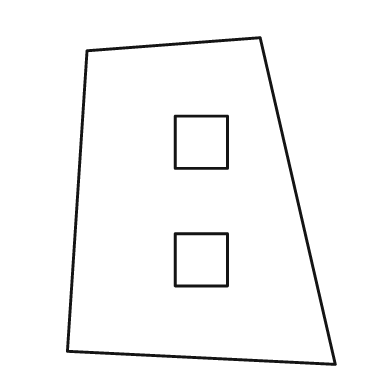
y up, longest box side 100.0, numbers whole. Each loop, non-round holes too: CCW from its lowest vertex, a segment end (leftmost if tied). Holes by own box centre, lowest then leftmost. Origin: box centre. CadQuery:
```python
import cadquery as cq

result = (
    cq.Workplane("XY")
    .moveTo(41.0, -50.0)
    .lineTo(18.0, 50.0)
    .lineTo(-35.0, 46.0)
    .lineTo(-41.0, -46.0)
    .close()
    .moveTo(-8.0, -26.0)
    .lineTo(8.0, -26.0)
    .lineTo(8.0, -10.0)
    .lineTo(-8.0, -10.0)
    .close()
    .moveTo(-8.0, 10.0)
    .lineTo(8.0, 10.0)
    .lineTo(8.0, 26.0)
    .lineTo(-8.0, 26.0)
    .close()
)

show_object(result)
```